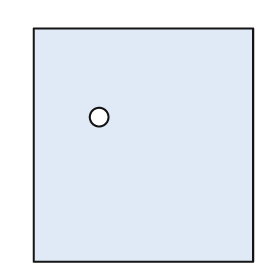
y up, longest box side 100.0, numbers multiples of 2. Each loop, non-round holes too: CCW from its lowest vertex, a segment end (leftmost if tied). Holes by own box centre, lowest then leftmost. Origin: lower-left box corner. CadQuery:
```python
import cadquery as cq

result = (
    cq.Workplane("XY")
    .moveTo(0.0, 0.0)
    .lineTo(94.0, 0.0)
    .lineTo(94.0, 100.0)
    .lineTo(0.0, 100.0)
    .close()
    .moveTo(28.0, 62.0)
    .circle(4.0)
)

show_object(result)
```